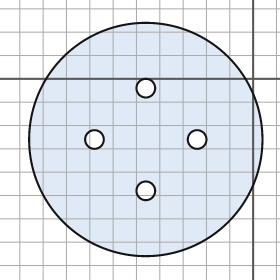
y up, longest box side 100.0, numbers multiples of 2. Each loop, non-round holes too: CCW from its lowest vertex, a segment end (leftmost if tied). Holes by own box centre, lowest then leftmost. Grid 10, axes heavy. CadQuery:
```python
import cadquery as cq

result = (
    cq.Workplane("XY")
    .moveTo(-46.0, -26.0)
    .circle(50.0)
    .moveTo(-46.0, -48.0)
    .circle(4.0)
    .moveTo(-68.0, -26.0)
    .circle(4.0)
    .moveTo(-24.0, -26.0)
    .circle(4.0)
    .moveTo(-46.0, -4.0)
    .circle(4.0)
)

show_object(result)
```